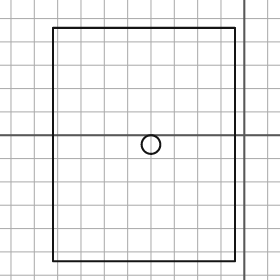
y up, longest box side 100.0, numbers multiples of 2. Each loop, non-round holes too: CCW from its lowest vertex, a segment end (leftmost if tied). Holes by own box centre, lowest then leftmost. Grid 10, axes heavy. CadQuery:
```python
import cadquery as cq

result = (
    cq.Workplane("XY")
    .moveTo(-82.0, -54.0)
    .lineTo(-4.0, -54.0)
    .lineTo(-4.0, 46.0)
    .lineTo(-82.0, 46.0)
    .close()
    .moveTo(-40.0, -4.0)
    .circle(4.0)
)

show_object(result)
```